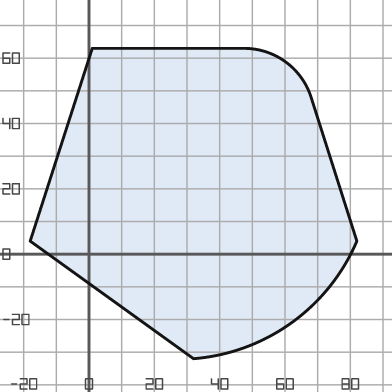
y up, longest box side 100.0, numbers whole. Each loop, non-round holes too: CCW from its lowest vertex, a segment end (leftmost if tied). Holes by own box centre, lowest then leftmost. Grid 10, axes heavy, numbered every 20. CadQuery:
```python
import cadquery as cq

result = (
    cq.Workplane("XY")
    .moveTo(32.0, -32.0)
    .threePointArc((62.0, -21.0), (82.0, 4.0))
    .lineTo(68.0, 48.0)
    .threePointArc((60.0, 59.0), (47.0, 63.0))
    .lineTo(1.0, 63.0)
    .lineTo(-18.0, 4.0)
    .close()
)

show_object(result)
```